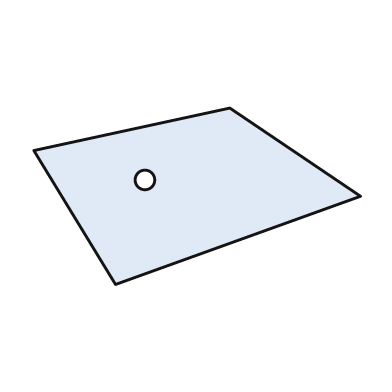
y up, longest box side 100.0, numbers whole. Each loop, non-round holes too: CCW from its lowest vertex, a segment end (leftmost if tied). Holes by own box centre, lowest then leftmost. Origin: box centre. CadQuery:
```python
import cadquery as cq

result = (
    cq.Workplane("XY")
    .moveTo(-25.0, -27.0)
    .lineTo(50.0, 0.0)
    .lineTo(10.0, 27.0)
    .lineTo(-50.0, 14.0)
    .close()
    .moveTo(-16.0, 5.0)
    .circle(3.0)
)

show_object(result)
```